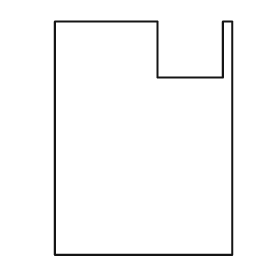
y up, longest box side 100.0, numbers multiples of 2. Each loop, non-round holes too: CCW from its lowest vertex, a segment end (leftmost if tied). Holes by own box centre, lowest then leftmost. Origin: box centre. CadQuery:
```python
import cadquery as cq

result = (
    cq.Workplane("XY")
    .moveTo(-38.0, -50.0)
    .lineTo(38.0, -50.0)
    .lineTo(38.0, 50.0)
    .lineTo(34.0, 50.0)
    .lineTo(34.0, 26.0)
    .lineTo(6.0, 26.0)
    .lineTo(6.0, 50.0)
    .lineTo(-38.0, 50.0)
    .close()
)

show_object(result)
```